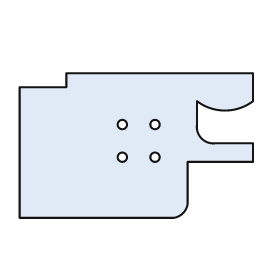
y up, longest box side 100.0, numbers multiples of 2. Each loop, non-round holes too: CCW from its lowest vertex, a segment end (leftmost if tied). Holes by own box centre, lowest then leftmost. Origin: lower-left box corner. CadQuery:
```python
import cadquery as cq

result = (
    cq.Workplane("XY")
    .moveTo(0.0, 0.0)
    .lineTo(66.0, 0.0)
    .threePointArc((70.0, 2.0), (72.0, 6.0))
    .lineTo(72.0, 24.0)
    .lineTo(100.0, 24.0)
    .lineTo(100.0, 32.0)
    .lineTo(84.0, 32.0)
    .threePointArc((78.0, 34.0), (76.0, 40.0))
    .lineTo(76.0, 50.0)
    .threePointArc((88.0, 46.0), (100.0, 50.0))
    .lineTo(100.0, 62.0)
    .lineTo(20.0, 62.0)
    .lineTo(20.0, 56.0)
    .lineTo(0.0, 56.0)
    .close()
    .moveTo(44.0, 26.0)
    .circle(2.0)
    .moveTo(58.0, 26.0)
    .circle(2.0)
    .moveTo(44.0, 40.0)
    .circle(2.0)
    .moveTo(58.0, 40.0)
    .circle(2.0)
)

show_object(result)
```